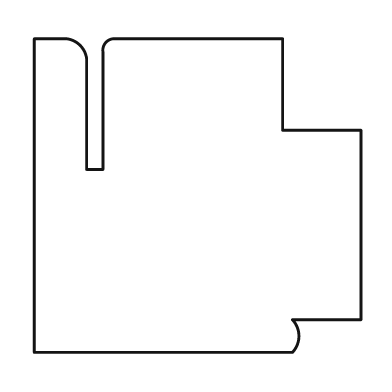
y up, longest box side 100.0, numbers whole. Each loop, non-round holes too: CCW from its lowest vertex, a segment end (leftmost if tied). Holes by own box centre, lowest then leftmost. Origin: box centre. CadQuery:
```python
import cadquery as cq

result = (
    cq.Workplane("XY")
    .moveTo(-50.0, -48.0)
    .lineTo(29.0, -48.0)
    .threePointArc((31.0, -43.0), (29.0, -38.0))
    .lineTo(50.0, -38.0)
    .lineTo(50.0, 20.0)
    .lineTo(26.0, 20.0)
    .lineTo(26.0, 48.0)
    .lineTo(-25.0, 48.0)
    .threePointArc((-28.0, 47.0), (-29.0, 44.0))
    .lineTo(-29.0, 8.0)
    .lineTo(-34.0, 8.0)
    .lineTo(-34.0, 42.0)
    .threePointArc((-36.0, 46.0), (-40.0, 48.0))
    .lineTo(-50.0, 48.0)
    .close()
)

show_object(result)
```